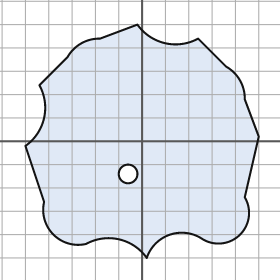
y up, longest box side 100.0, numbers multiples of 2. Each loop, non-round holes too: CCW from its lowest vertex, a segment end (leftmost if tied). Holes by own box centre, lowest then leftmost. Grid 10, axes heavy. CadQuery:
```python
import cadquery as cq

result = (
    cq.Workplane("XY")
    .moveTo(2.0, -50.0)
    .threePointArc((12.0, -40.0), (26.0, -42.0))
    .threePointArc((42.0, -40.0), (44.0, -24.0))
    .lineTo(50.0, 2.0)
    .lineTo(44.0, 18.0)
    .threePointArc((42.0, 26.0), (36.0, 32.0))
    .lineTo(24.0, 44.0)
    .threePointArc((10.0, 42.0), (-2.0, 50.0))
    .lineTo(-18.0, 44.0)
    .threePointArc((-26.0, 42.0), (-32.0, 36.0))
    .lineTo(-44.0, 24.0)
    .threePointArc((-42.0, 10.0), (-50.0, -2.0))
    .lineTo(-42.0, -26.0)
    .threePointArc((-38.0, -40.0), (-24.0, -44.0))
    .threePointArc((-10.0, -42.0), (2.0, -50.0))
    .close()
    .moveTo(-6.0, -14.0)
    .circle(4.0)
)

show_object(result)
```